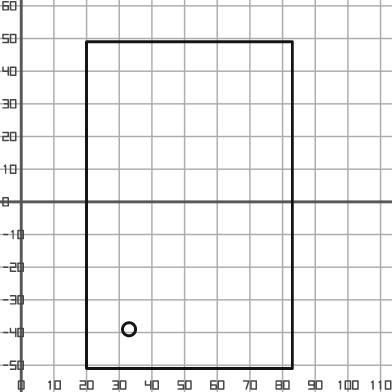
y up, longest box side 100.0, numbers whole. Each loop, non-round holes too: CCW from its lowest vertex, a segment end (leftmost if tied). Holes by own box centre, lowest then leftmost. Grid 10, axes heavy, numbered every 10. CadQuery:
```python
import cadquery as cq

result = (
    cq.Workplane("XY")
    .moveTo(20.0, -51.0)
    .lineTo(83.0, -51.0)
    .lineTo(83.0, 49.0)
    .lineTo(20.0, 49.0)
    .close()
    .moveTo(33.0, -39.0)
    .circle(2.0)
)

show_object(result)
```